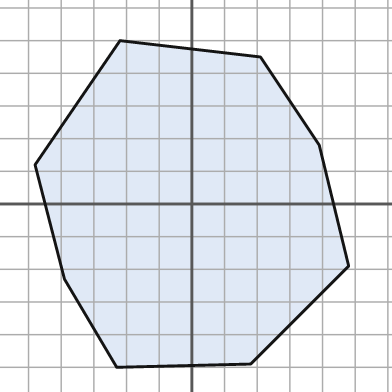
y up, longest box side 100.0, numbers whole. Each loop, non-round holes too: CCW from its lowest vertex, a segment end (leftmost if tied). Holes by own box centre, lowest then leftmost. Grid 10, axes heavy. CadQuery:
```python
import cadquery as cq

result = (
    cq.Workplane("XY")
    .moveTo(-23.0, -50.0)
    .lineTo(18.0, -49.0)
    .lineTo(48.0, -19.0)
    .lineTo(39.0, 18.0)
    .lineTo(21.0, 45.0)
    .lineTo(-22.0, 50.0)
    .lineTo(-48.0, 12.0)
    .lineTo(-39.0, -23.0)
    .close()
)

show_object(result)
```